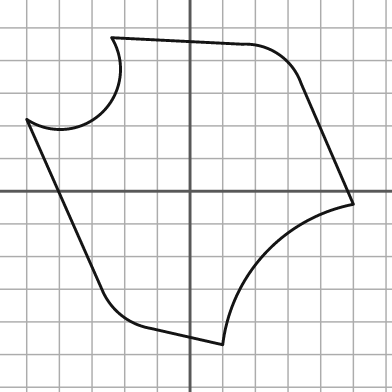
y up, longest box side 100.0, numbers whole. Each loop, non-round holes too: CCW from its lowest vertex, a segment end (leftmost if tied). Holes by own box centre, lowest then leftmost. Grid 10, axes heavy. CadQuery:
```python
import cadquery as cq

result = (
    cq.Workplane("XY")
    .moveTo(10.0, -47.0)
    .threePointArc((23.0, -19.0), (50.0, -4.0))
    .lineTo(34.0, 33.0)
    .threePointArc((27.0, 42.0), (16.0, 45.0))
    .lineTo(-24.0, 47.0)
    .threePointArc((-27.0, 24.0), (-50.0, 22.0))
    .lineTo(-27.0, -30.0)
    .threePointArc((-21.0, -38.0), (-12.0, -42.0))
    .close()
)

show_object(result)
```